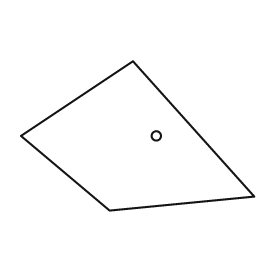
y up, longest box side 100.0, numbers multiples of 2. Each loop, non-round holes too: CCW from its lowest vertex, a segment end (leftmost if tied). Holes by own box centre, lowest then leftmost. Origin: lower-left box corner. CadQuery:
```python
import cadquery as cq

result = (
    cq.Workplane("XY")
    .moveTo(38.0, 0.0)
    .lineTo(100.0, 6.0)
    .lineTo(48.0, 64.0)
    .lineTo(0.0, 32.0)
    .close()
    .moveTo(58.0, 32.0)
    .circle(2.0)
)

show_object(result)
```